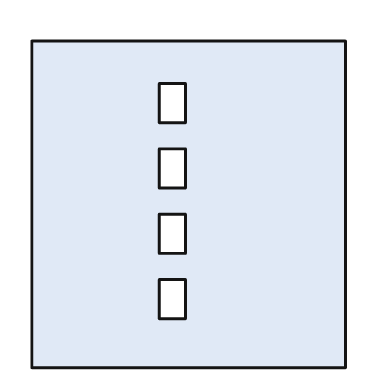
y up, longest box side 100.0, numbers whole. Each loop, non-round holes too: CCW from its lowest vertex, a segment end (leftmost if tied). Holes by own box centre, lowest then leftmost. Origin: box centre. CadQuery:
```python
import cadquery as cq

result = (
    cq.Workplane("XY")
    .moveTo(-48.0, -50.0)
    .lineTo(48.0, -50.0)
    .lineTo(48.0, 50.0)
    .lineTo(-48.0, 50.0)
    .close()
    .moveTo(-9.0, -35.0)
    .lineTo(-1.0, -35.0)
    .lineTo(-1.0, -23.0)
    .lineTo(-9.0, -23.0)
    .close()
    .moveTo(-9.0, -15.0)
    .lineTo(-1.0, -15.0)
    .lineTo(-1.0, -3.0)
    .lineTo(-9.0, -3.0)
    .close()
    .moveTo(-9.0, 5.0)
    .lineTo(-1.0, 5.0)
    .lineTo(-1.0, 17.0)
    .lineTo(-9.0, 17.0)
    .close()
    .moveTo(-9.0, 25.0)
    .lineTo(-1.0, 25.0)
    .lineTo(-1.0, 37.0)
    .lineTo(-9.0, 37.0)
    .close()
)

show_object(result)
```